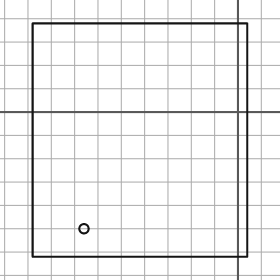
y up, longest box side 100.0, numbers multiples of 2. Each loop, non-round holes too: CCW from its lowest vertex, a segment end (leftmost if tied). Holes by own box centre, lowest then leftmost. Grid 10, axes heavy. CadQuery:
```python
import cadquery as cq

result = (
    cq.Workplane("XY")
    .moveTo(-88.0, -62.0)
    .lineTo(4.0, -62.0)
    .lineTo(4.0, 38.0)
    .lineTo(-88.0, 38.0)
    .close()
    .moveTo(-66.0, -50.0)
    .circle(2.0)
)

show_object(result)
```